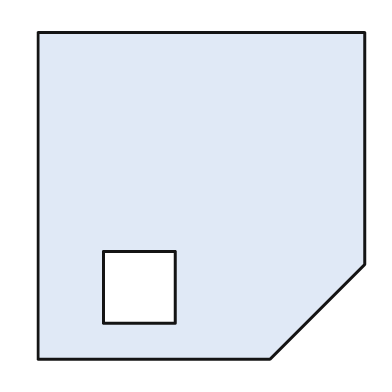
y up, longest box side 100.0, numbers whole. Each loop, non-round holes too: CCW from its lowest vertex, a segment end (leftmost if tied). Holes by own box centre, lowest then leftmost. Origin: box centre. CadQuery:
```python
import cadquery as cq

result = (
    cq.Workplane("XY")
    .moveTo(-50.0, -50.0)
    .lineTo(21.0, -50.0)
    .lineTo(50.0, -21.0)
    .lineTo(50.0, 50.0)
    .lineTo(-50.0, 50.0)
    .close()
    .moveTo(-30.0, -39.0)
    .lineTo(-8.0, -39.0)
    .lineTo(-8.0, -17.0)
    .lineTo(-30.0, -17.0)
    .close()
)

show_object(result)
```